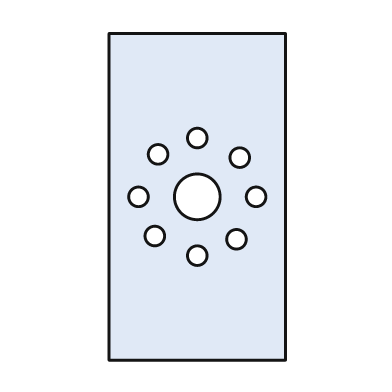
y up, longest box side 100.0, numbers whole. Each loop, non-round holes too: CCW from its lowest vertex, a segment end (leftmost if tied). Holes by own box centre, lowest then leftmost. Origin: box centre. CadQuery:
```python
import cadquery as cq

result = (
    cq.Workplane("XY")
    .moveTo(-27.0, -50.0)
    .lineTo(27.0, -50.0)
    .lineTo(27.0, 50.0)
    .lineTo(-27.0, 50.0)
    .close()
    .moveTo(0.0, -18.0)
    .circle(3.0)
    .moveTo(12.0, -13.0)
    .circle(3.0)
    .moveTo(-13.0, -12.0)
    .circle(3.0)
    .moveTo(-18.0, 0.0)
    .circle(3.0)
    .moveTo(0.0, 0.0)
    .circle(7.0)
    .moveTo(18.0, 0.0)
    .circle(3.0)
    .moveTo(13.0, 12.0)
    .circle(3.0)
    .moveTo(-12.0, 13.0)
    .circle(3.0)
    .moveTo(0.0, 18.0)
    .circle(3.0)
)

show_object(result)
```